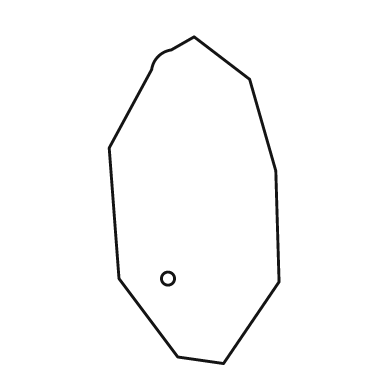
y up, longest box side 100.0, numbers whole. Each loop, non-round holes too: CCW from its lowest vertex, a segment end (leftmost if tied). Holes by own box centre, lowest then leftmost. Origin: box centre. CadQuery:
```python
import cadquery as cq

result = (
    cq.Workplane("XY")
    .moveTo(9.0, -50.0)
    .lineTo(26.0, -25.0)
    .lineTo(25.0, 9.0)
    .lineTo(17.0, 37.0)
    .lineTo(0.0, 50.0)
    .lineTo(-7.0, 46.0)
    .threePointArc((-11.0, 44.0), (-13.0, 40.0))
    .lineTo(-26.0, 16.0)
    .lineTo(-23.0, -24.0)
    .lineTo(-5.0, -48.0)
    .close()
    .moveTo(-8.0, -24.0)
    .circle(2.0)
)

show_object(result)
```